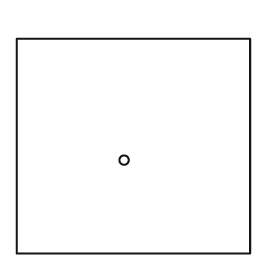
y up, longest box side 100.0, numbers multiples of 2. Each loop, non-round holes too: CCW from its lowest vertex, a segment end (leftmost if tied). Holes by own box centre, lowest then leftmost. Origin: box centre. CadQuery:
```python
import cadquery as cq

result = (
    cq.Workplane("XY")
    .moveTo(-50.0, -46.0)
    .lineTo(50.0, -46.0)
    .lineTo(50.0, 46.0)
    .lineTo(-50.0, 46.0)
    .close()
    .moveTo(-4.0, -6.0)
    .circle(2.0)
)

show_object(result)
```